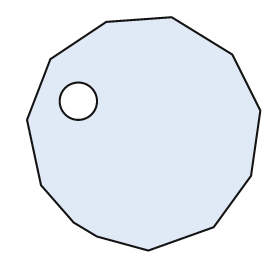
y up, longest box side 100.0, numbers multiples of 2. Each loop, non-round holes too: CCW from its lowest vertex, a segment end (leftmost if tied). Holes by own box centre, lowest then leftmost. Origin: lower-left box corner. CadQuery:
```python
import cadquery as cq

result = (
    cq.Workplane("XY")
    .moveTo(52.0, 0.0)
    .lineTo(80.0, 10.0)
    .lineTo(96.0, 32.0)
    .lineTo(100.0, 60.0)
    .lineTo(88.0, 84.0)
    .lineTo(62.0, 100.0)
    .lineTo(34.0, 98.0)
    .lineTo(10.0, 82.0)
    .lineTo(0.0, 56.0)
    .lineTo(6.0, 28.0)
    .lineTo(20.0, 12.0)
    .lineTo(30.0, 6.0)
    .close()
    .moveTo(22.0, 64.0)
    .circle(8.0)
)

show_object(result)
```